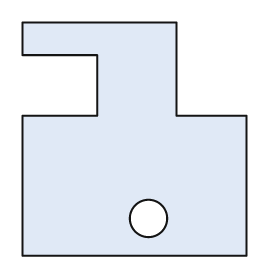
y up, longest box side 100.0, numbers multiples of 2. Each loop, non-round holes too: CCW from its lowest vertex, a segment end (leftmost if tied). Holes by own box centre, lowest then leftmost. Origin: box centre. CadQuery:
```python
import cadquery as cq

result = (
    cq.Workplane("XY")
    .moveTo(-48.0, -50.0)
    .lineTo(48.0, -50.0)
    .lineTo(48.0, 10.0)
    .lineTo(18.0, 10.0)
    .lineTo(18.0, 50.0)
    .lineTo(-48.0, 50.0)
    .lineTo(-48.0, 36.0)
    .lineTo(-16.0, 36.0)
    .lineTo(-16.0, 10.0)
    .lineTo(-48.0, 10.0)
    .close()
    .moveTo(6.0, -34.0)
    .circle(8.0)
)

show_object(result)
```